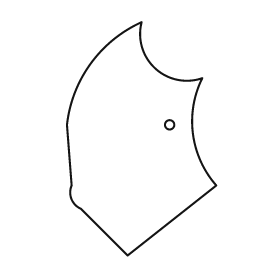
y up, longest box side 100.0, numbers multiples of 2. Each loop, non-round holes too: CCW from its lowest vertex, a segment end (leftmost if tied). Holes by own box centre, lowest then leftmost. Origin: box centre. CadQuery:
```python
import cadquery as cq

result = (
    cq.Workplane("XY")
    .moveTo(-6.0, -50.0)
    .lineTo(32.0, -20.0)
    .threePointArc((22.0, 2.0), (26.0, 26.0))
    .threePointArc((6.0, 30.0), (0.0, 50.0))
    .threePointArc((-22.0, 32.0), (-32.0, 6.0))
    .lineTo(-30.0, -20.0)
    .threePointArc((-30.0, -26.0), (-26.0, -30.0))
    .close()
    .moveTo(12.0, 6.0)
    .circle(2.0)
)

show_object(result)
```